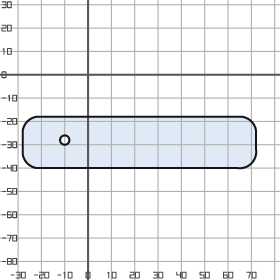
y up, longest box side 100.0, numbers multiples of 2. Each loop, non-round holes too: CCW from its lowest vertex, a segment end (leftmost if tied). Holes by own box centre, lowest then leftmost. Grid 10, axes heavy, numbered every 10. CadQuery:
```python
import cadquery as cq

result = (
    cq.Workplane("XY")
    .moveTo(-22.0, -40.0)
    .lineTo(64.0, -40.0)
    .threePointArc((70.0, -38.0), (72.0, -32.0))
    .lineTo(72.0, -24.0)
    .threePointArc((70.0, -20.0), (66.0, -18.0))
    .lineTo(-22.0, -18.0)
    .threePointArc((-26.0, -20.0), (-28.0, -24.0))
    .lineTo(-28.0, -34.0)
    .threePointArc((-26.0, -38.0), (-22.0, -40.0))
    .close()
    .moveTo(-10.0, -28.0)
    .circle(2.0)
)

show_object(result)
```